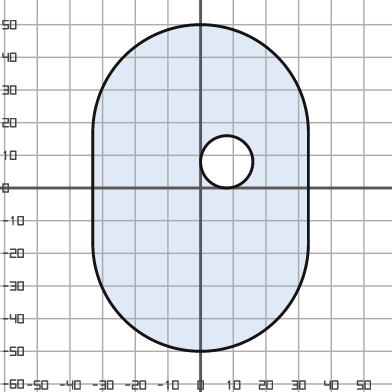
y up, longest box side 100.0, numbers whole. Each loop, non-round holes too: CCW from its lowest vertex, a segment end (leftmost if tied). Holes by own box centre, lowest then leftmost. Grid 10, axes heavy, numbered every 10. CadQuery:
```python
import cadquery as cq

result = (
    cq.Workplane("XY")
    .moveTo(-33.0, -17.0)
    .threePointArc((0.0, -50.0), (33.0, -17.0))
    .lineTo(33.0, 17.0)
    .threePointArc((0.0, 50.0), (-33.0, 17.0))
    .close()
    .moveTo(8.0, 8.0)
    .circle(8.0)
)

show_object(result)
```